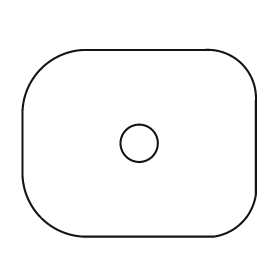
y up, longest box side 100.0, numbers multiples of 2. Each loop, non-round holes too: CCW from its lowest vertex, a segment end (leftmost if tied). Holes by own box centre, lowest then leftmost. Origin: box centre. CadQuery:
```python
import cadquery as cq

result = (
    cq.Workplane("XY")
    .moveTo(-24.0, -40.0)
    .lineTo(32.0, -40.0)
    .threePointArc((44.0, -34.0), (50.0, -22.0))
    .lineTo(50.0, 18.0)
    .threePointArc((44.0, 34.0), (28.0, 40.0))
    .lineTo(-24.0, 40.0)
    .threePointArc((-42.0, 32.0), (-50.0, 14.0))
    .lineTo(-50.0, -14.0)
    .threePointArc((-42.0, -32.0), (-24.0, -40.0))
    .close()
    .moveTo(0.0, 0.0)
    .circle(8.0)
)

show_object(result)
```